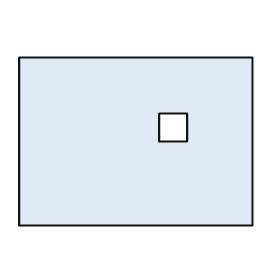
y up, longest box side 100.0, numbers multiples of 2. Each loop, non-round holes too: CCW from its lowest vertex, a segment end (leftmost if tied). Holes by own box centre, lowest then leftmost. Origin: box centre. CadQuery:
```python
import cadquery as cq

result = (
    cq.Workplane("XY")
    .moveTo(-50.0, -36.0)
    .lineTo(50.0, -36.0)
    .lineTo(50.0, 36.0)
    .lineTo(-50.0, 36.0)
    .close()
    .moveTo(10.0, 0.0)
    .lineTo(22.0, 0.0)
    .lineTo(22.0, 12.0)
    .lineTo(10.0, 12.0)
    .close()
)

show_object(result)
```